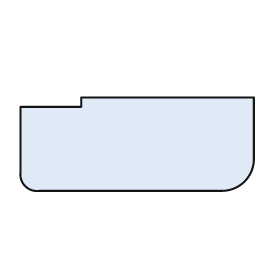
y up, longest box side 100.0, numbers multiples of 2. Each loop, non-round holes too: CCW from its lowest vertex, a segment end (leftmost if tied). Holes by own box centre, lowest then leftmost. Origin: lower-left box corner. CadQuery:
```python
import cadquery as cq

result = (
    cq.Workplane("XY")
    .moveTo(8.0, 0.0)
    .lineTo(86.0, 0.0)
    .threePointArc((96.0, 4.0), (100.0, 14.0))
    .lineTo(100.0, 40.0)
    .lineTo(26.0, 40.0)
    .lineTo(26.0, 36.0)
    .lineTo(0.0, 36.0)
    .lineTo(0.0, 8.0)
    .threePointArc((2.0, 2.0), (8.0, 0.0))
    .close()
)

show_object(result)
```